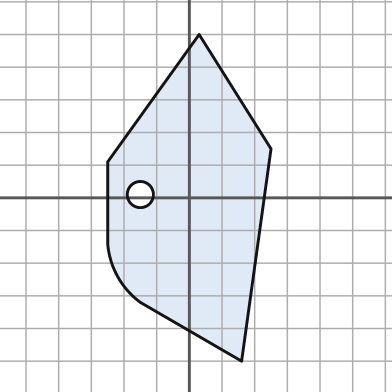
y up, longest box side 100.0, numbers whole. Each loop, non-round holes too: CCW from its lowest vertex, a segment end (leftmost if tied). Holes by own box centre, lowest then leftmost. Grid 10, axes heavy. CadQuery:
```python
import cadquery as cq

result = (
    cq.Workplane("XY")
    .moveTo(16.0, -50.0)
    .lineTo(25.0, 15.0)
    .lineTo(3.0, 50.0)
    .lineTo(-25.0, 11.0)
    .lineTo(-25.0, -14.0)
    .threePointArc((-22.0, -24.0), (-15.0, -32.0))
    .close()
    .moveTo(-15.0, 1.0)
    .circle(4.0)
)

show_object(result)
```